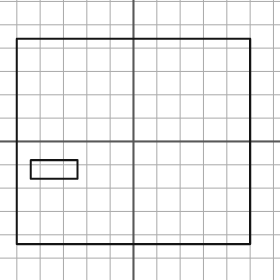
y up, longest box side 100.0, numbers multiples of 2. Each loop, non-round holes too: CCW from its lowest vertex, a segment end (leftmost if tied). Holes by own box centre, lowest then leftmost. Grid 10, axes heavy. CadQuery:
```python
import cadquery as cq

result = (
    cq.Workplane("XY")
    .moveTo(-50.0, -44.0)
    .lineTo(50.0, -44.0)
    .lineTo(50.0, 44.0)
    .lineTo(-50.0, 44.0)
    .close()
    .moveTo(-44.0, -16.0)
    .lineTo(-24.0, -16.0)
    .lineTo(-24.0, -8.0)
    .lineTo(-44.0, -8.0)
    .close()
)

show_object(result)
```